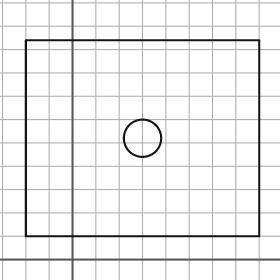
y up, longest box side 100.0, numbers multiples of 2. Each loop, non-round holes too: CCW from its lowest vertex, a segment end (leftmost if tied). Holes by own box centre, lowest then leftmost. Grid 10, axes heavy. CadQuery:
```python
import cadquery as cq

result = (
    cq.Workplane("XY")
    .moveTo(-20.0, 10.0)
    .lineTo(80.0, 10.0)
    .lineTo(80.0, 94.0)
    .lineTo(-20.0, 94.0)
    .close()
    .moveTo(30.0, 52.0)
    .circle(8.0)
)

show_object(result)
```